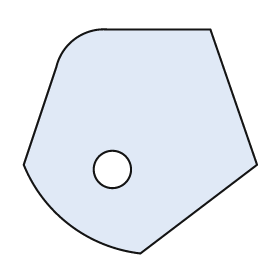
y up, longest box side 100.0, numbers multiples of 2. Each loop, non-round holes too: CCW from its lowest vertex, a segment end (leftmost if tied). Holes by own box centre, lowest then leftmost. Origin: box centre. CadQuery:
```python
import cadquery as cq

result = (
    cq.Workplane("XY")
    .moveTo(0.0, -48.0)
    .lineTo(50.0, -10.0)
    .lineTo(30.0, 48.0)
    .lineTo(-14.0, 48.0)
    .threePointArc((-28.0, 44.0), (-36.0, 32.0))
    .lineTo(-50.0, -10.0)
    .threePointArc((-30.0, -36.0), (0.0, -48.0))
    .close()
    .moveTo(-12.0, -12.0)
    .circle(8.0)
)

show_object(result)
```